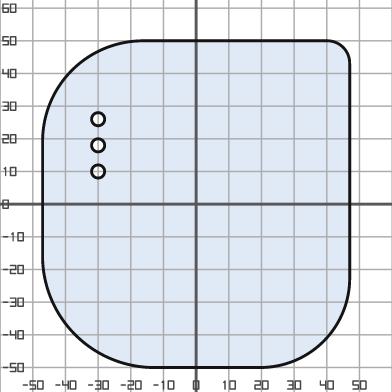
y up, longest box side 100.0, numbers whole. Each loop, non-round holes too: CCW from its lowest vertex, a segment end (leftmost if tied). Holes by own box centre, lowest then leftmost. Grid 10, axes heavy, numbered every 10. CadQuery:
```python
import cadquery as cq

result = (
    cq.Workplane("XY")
    .moveTo(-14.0, -50.0)
    .lineTo(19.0, -50.0)
    .threePointArc((39.0, -42.0), (47.0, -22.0))
    .lineTo(47.0, 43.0)
    .threePointArc((45.0, 48.0), (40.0, 50.0))
    .lineTo(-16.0, 50.0)
    .threePointArc((-38.0, 41.0), (-47.0, 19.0))
    .lineTo(-47.0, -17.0)
    .threePointArc((-37.0, -40.0), (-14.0, -50.0))
    .close()
    .moveTo(-30.0, 10.0)
    .circle(2.0)
    .moveTo(-30.0, 18.0)
    .circle(2.0)
    .moveTo(-30.0, 26.0)
    .circle(2.0)
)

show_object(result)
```